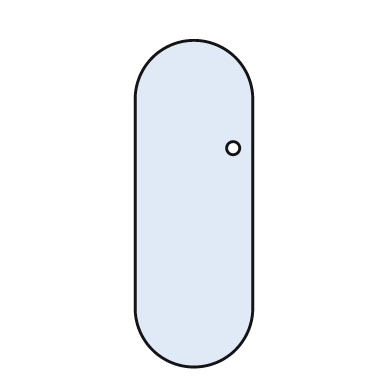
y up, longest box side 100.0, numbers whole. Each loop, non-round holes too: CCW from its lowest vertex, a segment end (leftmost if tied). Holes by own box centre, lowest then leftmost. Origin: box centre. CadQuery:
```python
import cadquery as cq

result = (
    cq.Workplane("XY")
    .moveTo(-18.0, -32.0)
    .threePointArc((0.0, -50.0), (18.0, -32.0))
    .lineTo(18.0, 32.0)
    .threePointArc((0.0, 50.0), (-18.0, 32.0))
    .close()
    .moveTo(12.0, 17.0)
    .circle(2.0)
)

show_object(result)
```